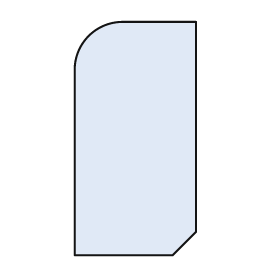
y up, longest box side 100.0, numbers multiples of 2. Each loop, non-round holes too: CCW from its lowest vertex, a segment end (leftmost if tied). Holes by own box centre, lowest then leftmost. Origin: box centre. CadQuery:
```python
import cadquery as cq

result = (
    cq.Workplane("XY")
    .moveTo(-26.0, -50.0)
    .lineTo(16.0, -50.0)
    .lineTo(26.0, -40.0)
    .lineTo(26.0, 50.0)
    .lineTo(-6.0, 50.0)
    .threePointArc((-20.0, 44.0), (-26.0, 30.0))
    .close()
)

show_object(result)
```